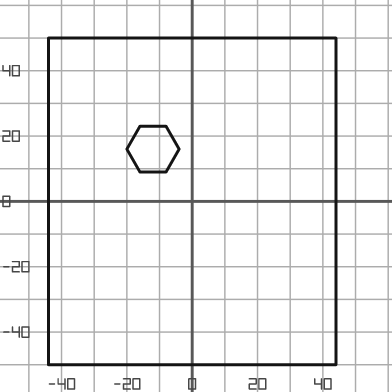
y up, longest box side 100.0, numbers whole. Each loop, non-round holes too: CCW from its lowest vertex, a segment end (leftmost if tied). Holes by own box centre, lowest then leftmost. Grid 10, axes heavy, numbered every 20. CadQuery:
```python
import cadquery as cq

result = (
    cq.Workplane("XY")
    .moveTo(-44.0, -50.0)
    .lineTo(44.0, -50.0)
    .lineTo(44.0, 50.0)
    .lineTo(-44.0, 50.0)
    .close()
    .moveTo(-16.0, 9.0)
    .lineTo(-8.0, 9.0)
    .lineTo(-4.0, 16.0)
    .lineTo(-8.0, 23.0)
    .lineTo(-16.0, 23.0)
    .lineTo(-20.0, 16.0)
    .close()
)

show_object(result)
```